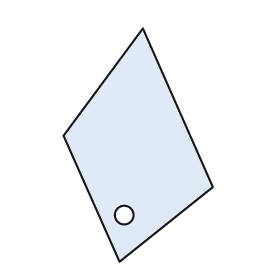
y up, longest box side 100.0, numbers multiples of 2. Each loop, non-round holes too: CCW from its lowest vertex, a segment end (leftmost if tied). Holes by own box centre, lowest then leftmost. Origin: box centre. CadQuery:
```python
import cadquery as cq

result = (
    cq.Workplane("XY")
    .moveTo(-8.0, -50.0)
    .lineTo(32.0, -18.0)
    .lineTo(2.0, 50.0)
    .lineTo(-32.0, 4.0)
    .close()
    .moveTo(-6.0, -30.0)
    .circle(4.0)
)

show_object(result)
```